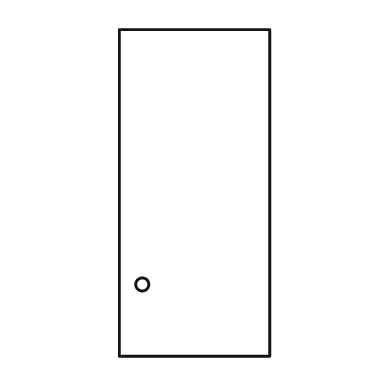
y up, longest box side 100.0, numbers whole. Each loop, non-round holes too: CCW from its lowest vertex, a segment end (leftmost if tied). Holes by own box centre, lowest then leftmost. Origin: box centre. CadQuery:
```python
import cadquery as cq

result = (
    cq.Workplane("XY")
    .moveTo(-23.0, -50.0)
    .lineTo(23.0, -50.0)
    .lineTo(23.0, 50.0)
    .lineTo(-23.0, 50.0)
    .close()
    .moveTo(-16.0, -28.0)
    .circle(2.0)
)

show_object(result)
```